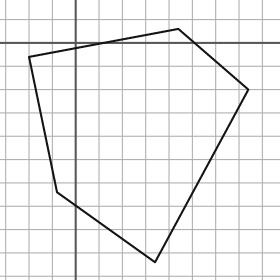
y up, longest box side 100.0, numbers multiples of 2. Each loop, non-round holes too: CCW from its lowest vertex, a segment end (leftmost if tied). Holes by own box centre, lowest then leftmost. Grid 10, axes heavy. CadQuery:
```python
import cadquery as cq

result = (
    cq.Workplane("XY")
    .moveTo(34.0, -94.0)
    .lineTo(74.0, -20.0)
    .lineTo(44.0, 6.0)
    .lineTo(-20.0, -6.0)
    .lineTo(-8.0, -64.0)
    .close()
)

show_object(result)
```